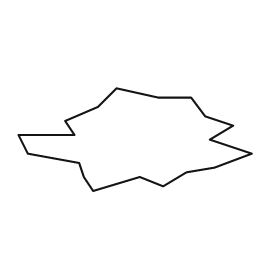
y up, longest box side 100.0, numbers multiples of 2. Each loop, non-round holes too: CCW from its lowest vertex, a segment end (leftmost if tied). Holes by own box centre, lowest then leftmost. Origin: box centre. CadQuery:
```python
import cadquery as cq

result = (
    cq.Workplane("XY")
    .moveTo(-18.0, -22.0)
    .lineTo(2.0, -16.0)
    .lineTo(12.0, -20.0)
    .lineTo(22.0, -14.0)
    .lineTo(34.0, -12.0)
    .lineTo(50.0, -6.0)
    .lineTo(32.0, 0.0)
    .lineTo(42.0, 6.0)
    .lineTo(30.0, 10.0)
    .lineTo(24.0, 18.0)
    .lineTo(10.0, 18.0)
    .lineTo(-8.0, 22.0)
    .lineTo(-16.0, 14.0)
    .lineTo(-30.0, 8.0)
    .lineTo(-26.0, 2.0)
    .lineTo(-50.0, 2.0)
    .lineTo(-46.0, -6.0)
    .lineTo(-24.0, -10.0)
    .lineTo(-22.0, -16.0)
    .close()
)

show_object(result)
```